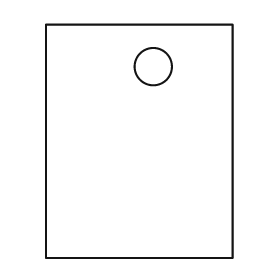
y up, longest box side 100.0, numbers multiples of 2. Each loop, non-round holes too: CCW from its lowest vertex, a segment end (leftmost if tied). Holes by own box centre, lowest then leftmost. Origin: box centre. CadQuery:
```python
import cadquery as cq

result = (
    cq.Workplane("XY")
    .moveTo(-40.0, -50.0)
    .lineTo(40.0, -50.0)
    .lineTo(40.0, 50.0)
    .lineTo(-40.0, 50.0)
    .close()
    .moveTo(6.0, 32.0)
    .circle(8.0)
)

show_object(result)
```